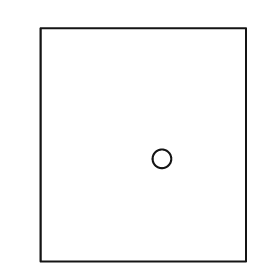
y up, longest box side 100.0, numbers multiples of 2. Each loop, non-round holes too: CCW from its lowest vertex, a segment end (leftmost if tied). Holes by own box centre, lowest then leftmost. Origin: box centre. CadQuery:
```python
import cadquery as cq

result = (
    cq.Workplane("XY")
    .moveTo(-44.0, -50.0)
    .lineTo(44.0, -50.0)
    .lineTo(44.0, 50.0)
    .lineTo(-44.0, 50.0)
    .close()
    .moveTo(8.0, -6.0)
    .circle(4.0)
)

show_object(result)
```